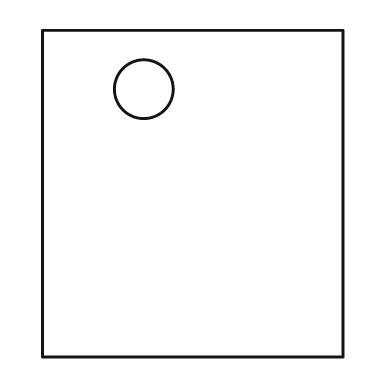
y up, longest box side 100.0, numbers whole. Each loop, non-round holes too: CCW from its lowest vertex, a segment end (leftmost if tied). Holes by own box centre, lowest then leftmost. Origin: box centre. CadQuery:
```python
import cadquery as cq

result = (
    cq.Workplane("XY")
    .moveTo(-46.0, -50.0)
    .lineTo(46.0, -50.0)
    .lineTo(46.0, 50.0)
    .lineTo(-46.0, 50.0)
    .close()
    .moveTo(-15.0, 32.0)
    .circle(9.0)
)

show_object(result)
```